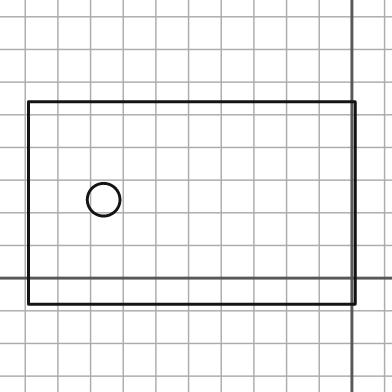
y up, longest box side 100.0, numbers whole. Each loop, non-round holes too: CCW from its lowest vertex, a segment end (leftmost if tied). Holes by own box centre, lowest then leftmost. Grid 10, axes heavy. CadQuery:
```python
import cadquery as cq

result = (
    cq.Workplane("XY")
    .moveTo(-99.0, -8.0)
    .lineTo(1.0, -8.0)
    .lineTo(1.0, 54.0)
    .lineTo(-99.0, 54.0)
    .close()
    .moveTo(-76.0, 24.0)
    .circle(5.0)
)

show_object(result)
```